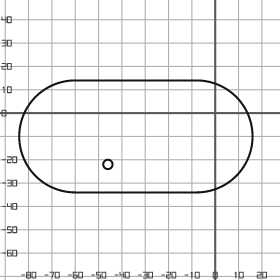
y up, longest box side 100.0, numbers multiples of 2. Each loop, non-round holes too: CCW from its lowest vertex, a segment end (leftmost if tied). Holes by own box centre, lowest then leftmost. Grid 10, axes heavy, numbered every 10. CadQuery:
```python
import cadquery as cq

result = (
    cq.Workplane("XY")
    .moveTo(-60.0, -34.0)
    .lineTo(-8.0, -34.0)
    .threePointArc((16.0, -10.0), (-8.0, 14.0))
    .lineTo(-60.0, 14.0)
    .threePointArc((-84.0, -10.0), (-60.0, -34.0))
    .close()
    .moveTo(-46.0, -22.0)
    .circle(2.0)
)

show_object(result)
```